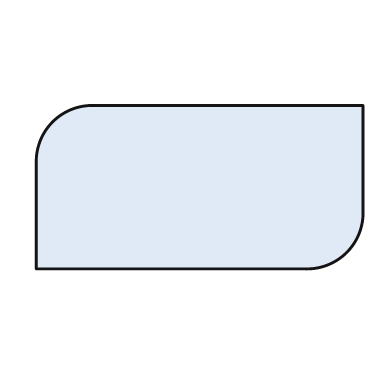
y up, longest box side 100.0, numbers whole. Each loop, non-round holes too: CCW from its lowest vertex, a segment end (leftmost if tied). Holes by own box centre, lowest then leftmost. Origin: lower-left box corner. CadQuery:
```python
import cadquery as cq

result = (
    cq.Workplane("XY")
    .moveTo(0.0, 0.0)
    .lineTo(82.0, 0.0)
    .threePointArc((95.0, 5.0), (100.0, 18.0))
    .lineTo(100.0, 50.0)
    .lineTo(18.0, 50.0)
    .threePointArc((5.0, 45.0), (0.0, 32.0))
    .close()
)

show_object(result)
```